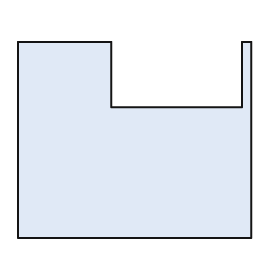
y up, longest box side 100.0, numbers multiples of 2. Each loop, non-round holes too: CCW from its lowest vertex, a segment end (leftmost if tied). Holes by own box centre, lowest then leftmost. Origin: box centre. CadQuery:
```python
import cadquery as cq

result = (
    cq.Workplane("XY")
    .moveTo(-50.0, -42.0)
    .lineTo(50.0, -42.0)
    .lineTo(50.0, 42.0)
    .lineTo(46.0, 42.0)
    .lineTo(46.0, 14.0)
    .lineTo(-10.0, 14.0)
    .lineTo(-10.0, 42.0)
    .lineTo(-50.0, 42.0)
    .close()
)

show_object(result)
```